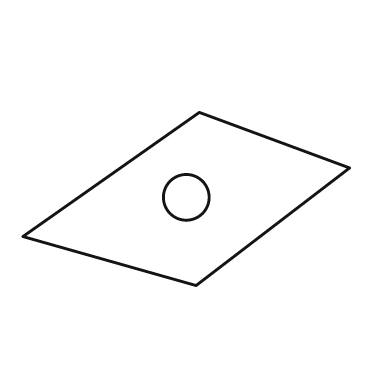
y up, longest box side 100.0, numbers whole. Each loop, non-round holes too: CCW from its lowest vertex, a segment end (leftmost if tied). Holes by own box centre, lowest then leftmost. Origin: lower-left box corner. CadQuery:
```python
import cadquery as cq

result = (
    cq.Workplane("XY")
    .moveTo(53.0, 0.0)
    .lineTo(100.0, 36.0)
    .lineTo(54.0, 53.0)
    .lineTo(0.0, 15.0)
    .close()
    .moveTo(50.0, 27.0)
    .circle(7.0)
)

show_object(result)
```